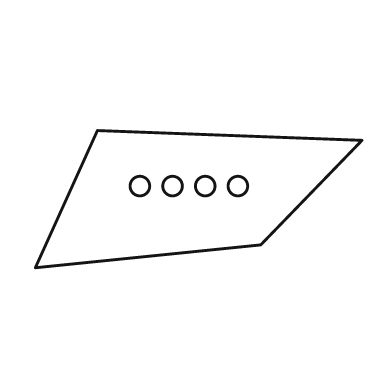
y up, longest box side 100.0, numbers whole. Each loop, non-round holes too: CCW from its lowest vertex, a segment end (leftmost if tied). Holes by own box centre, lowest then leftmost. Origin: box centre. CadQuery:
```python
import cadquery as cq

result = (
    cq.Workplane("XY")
    .moveTo(-50.0, -21.0)
    .lineTo(19.0, -14.0)
    .lineTo(50.0, 18.0)
    .lineTo(-31.0, 21.0)
    .close()
    .moveTo(-18.0, 4.0)
    .circle(3.0)
    .moveTo(-8.0, 4.0)
    .circle(3.0)
    .moveTo(2.0, 4.0)
    .circle(3.0)
    .moveTo(12.0, 4.0)
    .circle(3.0)
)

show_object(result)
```